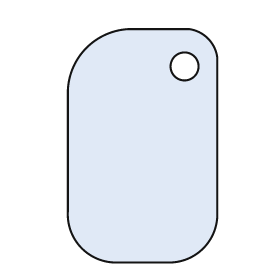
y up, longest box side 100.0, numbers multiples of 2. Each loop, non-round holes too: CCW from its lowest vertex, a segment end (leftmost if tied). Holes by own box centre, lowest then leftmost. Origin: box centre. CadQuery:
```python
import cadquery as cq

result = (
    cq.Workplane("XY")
    .moveTo(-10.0, -50.0)
    .lineTo(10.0, -50.0)
    .threePointArc((26.0, -44.0), (32.0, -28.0))
    .lineTo(32.0, 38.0)
    .threePointArc((28.0, 46.0), (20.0, 50.0))
    .lineTo(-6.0, 50.0)
    .threePointArc((-24.0, 42.0), (-32.0, 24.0))
    .lineTo(-32.0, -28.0)
    .threePointArc((-26.0, -44.0), (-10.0, -50.0))
    .close()
    .moveTo(18.0, 34.0)
    .circle(6.0)
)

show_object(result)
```